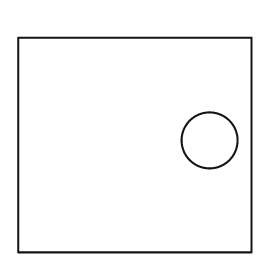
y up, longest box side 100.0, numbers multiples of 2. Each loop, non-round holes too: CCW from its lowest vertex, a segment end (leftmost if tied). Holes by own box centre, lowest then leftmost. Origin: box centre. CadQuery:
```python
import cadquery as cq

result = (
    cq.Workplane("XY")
    .moveTo(-50.0, -46.0)
    .lineTo(50.0, -46.0)
    .lineTo(50.0, 46.0)
    .lineTo(-50.0, 46.0)
    .close()
    .moveTo(32.0, 2.0)
    .circle(12.0)
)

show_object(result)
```